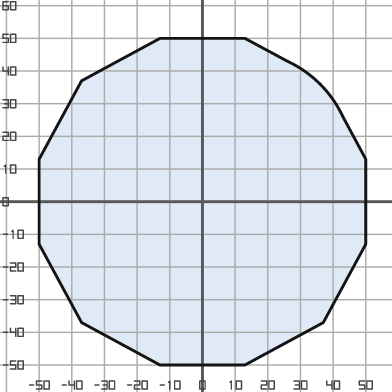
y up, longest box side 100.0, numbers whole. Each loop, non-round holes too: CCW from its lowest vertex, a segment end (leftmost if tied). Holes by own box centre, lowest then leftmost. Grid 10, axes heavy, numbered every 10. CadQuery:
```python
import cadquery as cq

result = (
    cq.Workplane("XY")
    .moveTo(-13.0, -50.0)
    .lineTo(13.0, -50.0)
    .lineTo(37.0, -37.0)
    .lineTo(50.0, -13.0)
    .lineTo(50.0, 13.0)
    .lineTo(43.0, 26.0)
    .threePointArc((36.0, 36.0), (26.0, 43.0))
    .lineTo(13.0, 50.0)
    .lineTo(-13.0, 50.0)
    .lineTo(-37.0, 37.0)
    .lineTo(-50.0, 13.0)
    .lineTo(-50.0, -13.0)
    .lineTo(-37.0, -37.0)
    .close()
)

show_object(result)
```